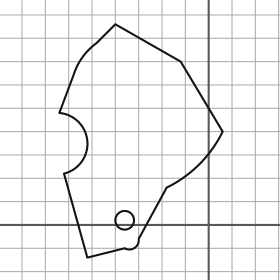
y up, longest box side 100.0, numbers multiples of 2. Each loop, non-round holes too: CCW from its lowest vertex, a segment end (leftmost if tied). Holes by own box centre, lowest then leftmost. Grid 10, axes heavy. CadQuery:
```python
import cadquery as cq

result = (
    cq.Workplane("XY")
    .moveTo(-52.0, -14.0)
    .lineTo(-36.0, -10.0)
    .threePointArc((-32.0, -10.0), (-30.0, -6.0))
    .lineTo(-18.0, 16.0)
    .threePointArc((-4.0, 26.0), (6.0, 40.0))
    .lineTo(-12.0, 70.0)
    .lineTo(-40.0, 86.0)
    .lineTo(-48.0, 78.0)
    .threePointArc((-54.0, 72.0), (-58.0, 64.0))
    .lineTo(-64.0, 48.0)
    .threePointArc((-52.0, 36.0), (-62.0, 22.0))
    .close()
    .moveTo(-36.0, 2.0)
    .circle(4.0)
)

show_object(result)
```